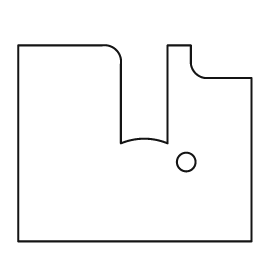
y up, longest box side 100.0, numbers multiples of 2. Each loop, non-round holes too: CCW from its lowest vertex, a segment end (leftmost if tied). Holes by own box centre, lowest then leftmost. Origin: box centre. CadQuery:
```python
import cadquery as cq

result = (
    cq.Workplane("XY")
    .moveTo(-50.0, -42.0)
    .lineTo(50.0, -42.0)
    .lineTo(50.0, 28.0)
    .lineTo(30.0, 28.0)
    .threePointArc((26.0, 30.0), (24.0, 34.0))
    .lineTo(24.0, 42.0)
    .lineTo(14.0, 42.0)
    .lineTo(14.0, 0.0)
    .threePointArc((4.0, 2.0), (-6.0, 0.0))
    .lineTo(-6.0, 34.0)
    .threePointArc((-8.0, 40.0), (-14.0, 42.0))
    .lineTo(-50.0, 42.0)
    .close()
    .moveTo(22.0, -8.0)
    .circle(4.0)
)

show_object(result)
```